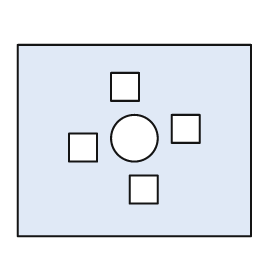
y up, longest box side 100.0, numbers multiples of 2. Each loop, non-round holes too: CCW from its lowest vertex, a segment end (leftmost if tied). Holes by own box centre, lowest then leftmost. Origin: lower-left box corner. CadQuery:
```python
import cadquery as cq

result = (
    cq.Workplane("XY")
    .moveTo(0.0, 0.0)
    .lineTo(100.0, 0.0)
    .lineTo(100.0, 82.0)
    .lineTo(0.0, 82.0)
    .close()
    .moveTo(48.0, 14.0)
    .lineTo(60.0, 14.0)
    .lineTo(60.0, 26.0)
    .lineTo(48.0, 26.0)
    .close()
    .moveTo(22.0, 32.0)
    .lineTo(34.0, 32.0)
    .lineTo(34.0, 44.0)
    .lineTo(22.0, 44.0)
    .close()
    .moveTo(50.0, 42.0)
    .circle(10.0)
    .moveTo(66.0, 40.0)
    .lineTo(78.0, 40.0)
    .lineTo(78.0, 52.0)
    .lineTo(66.0, 52.0)
    .close()
    .moveTo(40.0, 58.0)
    .lineTo(52.0, 58.0)
    .lineTo(52.0, 70.0)
    .lineTo(40.0, 70.0)
    .close()
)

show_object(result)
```